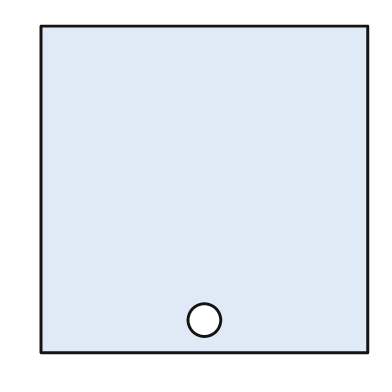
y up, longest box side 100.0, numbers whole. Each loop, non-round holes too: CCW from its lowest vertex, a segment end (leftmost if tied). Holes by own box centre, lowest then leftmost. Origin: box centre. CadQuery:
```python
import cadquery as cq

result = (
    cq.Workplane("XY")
    .moveTo(-50.0, -50.0)
    .lineTo(50.0, -50.0)
    .lineTo(50.0, 50.0)
    .lineTo(-50.0, 50.0)
    .close()
    .moveTo(0.0, -40.0)
    .circle(5.0)
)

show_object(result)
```